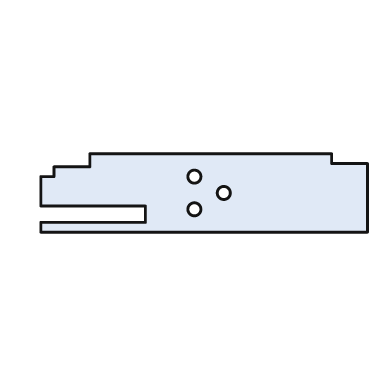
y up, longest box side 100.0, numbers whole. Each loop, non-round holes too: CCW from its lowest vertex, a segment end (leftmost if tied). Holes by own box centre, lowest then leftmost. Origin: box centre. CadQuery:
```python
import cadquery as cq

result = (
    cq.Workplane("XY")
    .moveTo(-50.0, -12.0)
    .lineTo(50.0, -12.0)
    .lineTo(50.0, 9.0)
    .lineTo(39.0, 9.0)
    .lineTo(39.0, 12.0)
    .lineTo(-35.0, 12.0)
    .lineTo(-35.0, 8.0)
    .lineTo(-46.0, 8.0)
    .lineTo(-46.0, 5.0)
    .lineTo(-50.0, 5.0)
    .lineTo(-50.0, -4.0)
    .lineTo(-18.0, -4.0)
    .lineTo(-18.0, -9.0)
    .lineTo(-50.0, -9.0)
    .close()
    .moveTo(-3.0, -5.0)
    .circle(2.0)
    .moveTo(6.0, 0.0)
    .circle(2.0)
    .moveTo(-3.0, 5.0)
    .circle(2.0)
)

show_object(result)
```